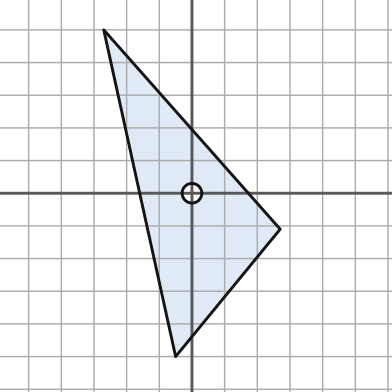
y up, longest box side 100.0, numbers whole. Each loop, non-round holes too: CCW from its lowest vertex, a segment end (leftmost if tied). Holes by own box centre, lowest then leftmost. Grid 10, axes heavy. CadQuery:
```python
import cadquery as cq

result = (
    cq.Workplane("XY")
    .moveTo(-5.0, -50.0)
    .lineTo(27.0, -11.0)
    .lineTo(-27.0, 50.0)
    .close()
    .moveTo(0.0, 0.0)
    .circle(3.0)
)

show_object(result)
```